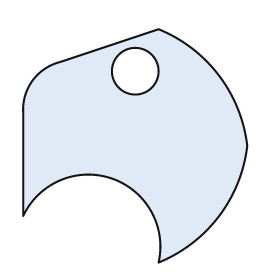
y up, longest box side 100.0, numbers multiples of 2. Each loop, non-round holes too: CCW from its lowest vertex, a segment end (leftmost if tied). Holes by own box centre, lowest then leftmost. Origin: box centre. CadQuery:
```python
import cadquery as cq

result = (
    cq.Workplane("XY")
    .moveTo(10.0, -50.0)
    .threePointArc((36.0, -30.0), (48.0, 0.0))
    .threePointArc((36.0, 30.0), (10.0, 50.0))
    .lineTo(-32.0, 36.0)
    .threePointArc((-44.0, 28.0), (-48.0, 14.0))
    .lineTo(-48.0, -30.0)
    .threePointArc((-10.0, -14.0), (10.0, -50.0))
    .close()
    .moveTo(0.0, 32.0)
    .circle(10.0)
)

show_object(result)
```